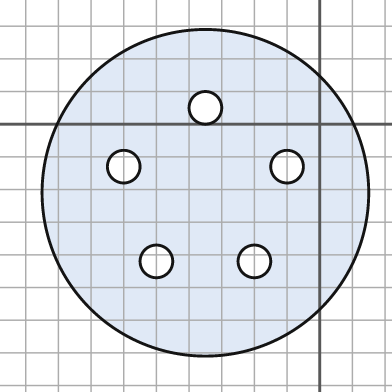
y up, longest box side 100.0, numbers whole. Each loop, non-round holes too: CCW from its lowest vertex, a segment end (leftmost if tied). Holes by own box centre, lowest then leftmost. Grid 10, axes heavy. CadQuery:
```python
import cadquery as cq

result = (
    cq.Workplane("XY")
    .moveTo(-35.0, -21.0)
    .circle(50.0)
    .moveTo(-50.0, -42.0)
    .circle(5.0)
    .moveTo(-20.0, -42.0)
    .circle(5.0)
    .moveTo(-60.0, -13.0)
    .circle(5.0)
    .moveTo(-10.0, -13.0)
    .circle(5.0)
    .moveTo(-35.0, 5.0)
    .circle(5.0)
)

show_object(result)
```